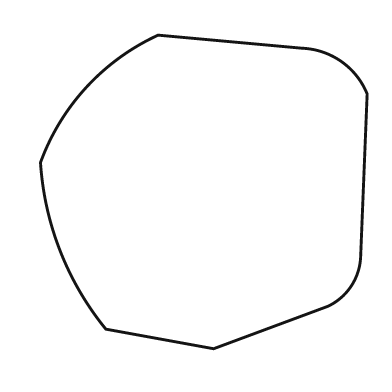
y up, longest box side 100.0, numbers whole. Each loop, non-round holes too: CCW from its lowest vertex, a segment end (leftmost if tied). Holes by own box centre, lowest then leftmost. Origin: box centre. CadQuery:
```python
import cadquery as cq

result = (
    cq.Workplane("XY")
    .moveTo(3.0, -48.0)
    .lineTo(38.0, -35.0)
    .threePointArc((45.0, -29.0), (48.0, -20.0))
    .lineTo(50.0, 30.0)
    .threePointArc((42.0, 40.0), (30.0, 44.0))
    .lineTo(-14.0, 48.0)
    .threePointArc((-36.0, 32.0), (-50.0, 9.0))
    .threePointArc((-44.0, -18.0), (-30.0, -42.0))
    .close()
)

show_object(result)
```